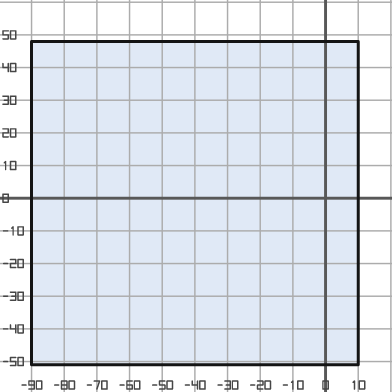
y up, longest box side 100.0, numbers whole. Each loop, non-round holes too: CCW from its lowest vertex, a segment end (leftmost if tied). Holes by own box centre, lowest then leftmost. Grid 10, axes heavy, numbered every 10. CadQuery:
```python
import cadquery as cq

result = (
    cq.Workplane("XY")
    .moveTo(-90.0, -51.0)
    .lineTo(10.0, -51.0)
    .lineTo(10.0, 48.0)
    .lineTo(-90.0, 48.0)
    .close()
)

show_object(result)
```